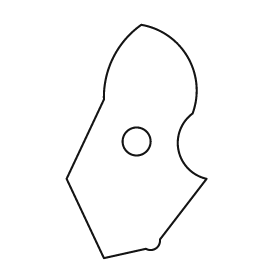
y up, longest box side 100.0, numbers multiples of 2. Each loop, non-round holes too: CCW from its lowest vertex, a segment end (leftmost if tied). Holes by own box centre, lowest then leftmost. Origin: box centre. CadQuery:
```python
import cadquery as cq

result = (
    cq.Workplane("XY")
    .moveTo(-14.0, -50.0)
    .lineTo(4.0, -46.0)
    .threePointArc((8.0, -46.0), (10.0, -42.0))
    .lineTo(30.0, -16.0)
    .threePointArc((18.0, -4.0), (24.0, 12.0))
    .threePointArc((22.0, 36.0), (2.0, 50.0))
    .threePointArc((-10.0, 36.0), (-14.0, 18.0))
    .lineTo(-30.0, -16.0)
    .close()
    .moveTo(0.0, 0.0)
    .circle(6.0)
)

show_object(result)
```